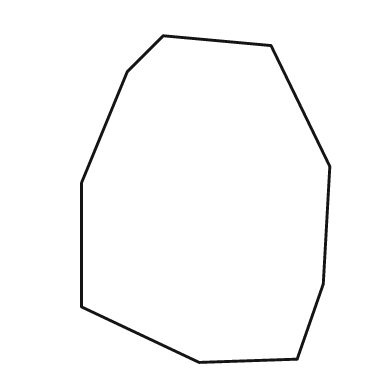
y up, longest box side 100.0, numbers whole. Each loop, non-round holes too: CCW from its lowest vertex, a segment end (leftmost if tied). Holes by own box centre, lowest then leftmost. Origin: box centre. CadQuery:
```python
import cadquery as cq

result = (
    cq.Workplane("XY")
    .moveTo(-2.0, -50.0)
    .lineTo(28.0, -49.0)
    .lineTo(36.0, -26.0)
    .lineTo(38.0, 10.0)
    .lineTo(20.0, 47.0)
    .lineTo(-13.0, 50.0)
    .lineTo(-24.0, 39.0)
    .lineTo(-38.0, 5.0)
    .lineTo(-38.0, -33.0)
    .close()
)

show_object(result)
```